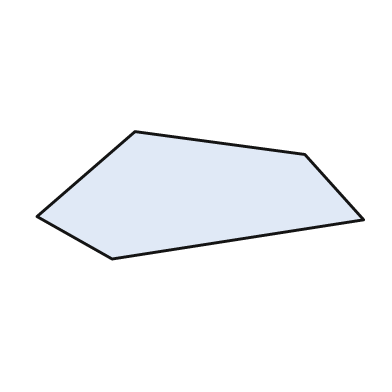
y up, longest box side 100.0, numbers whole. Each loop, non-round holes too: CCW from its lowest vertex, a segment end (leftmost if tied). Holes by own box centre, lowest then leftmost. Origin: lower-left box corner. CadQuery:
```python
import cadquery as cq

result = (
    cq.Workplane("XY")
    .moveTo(23.0, 0.0)
    .lineTo(100.0, 12.0)
    .lineTo(82.0, 32.0)
    .lineTo(30.0, 39.0)
    .lineTo(0.0, 13.0)
    .close()
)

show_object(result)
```